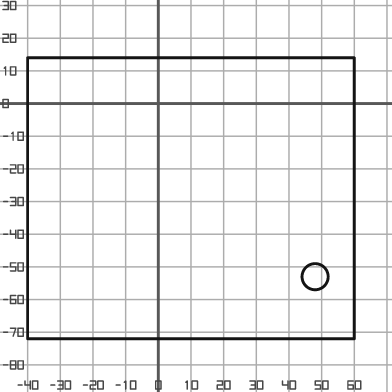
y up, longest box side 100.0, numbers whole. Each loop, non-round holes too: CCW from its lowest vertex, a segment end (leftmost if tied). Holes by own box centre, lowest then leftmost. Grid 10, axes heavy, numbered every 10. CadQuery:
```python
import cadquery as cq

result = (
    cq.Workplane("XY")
    .moveTo(-40.0, -72.0)
    .lineTo(60.0, -72.0)
    .lineTo(60.0, 14.0)
    .lineTo(-40.0, 14.0)
    .close()
    .moveTo(48.0, -53.0)
    .circle(4.0)
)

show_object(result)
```